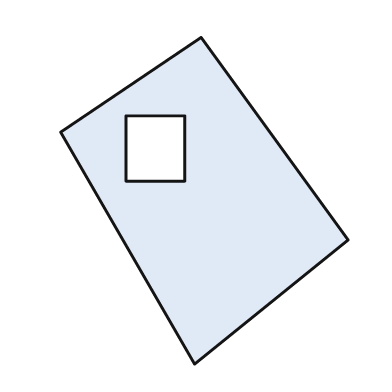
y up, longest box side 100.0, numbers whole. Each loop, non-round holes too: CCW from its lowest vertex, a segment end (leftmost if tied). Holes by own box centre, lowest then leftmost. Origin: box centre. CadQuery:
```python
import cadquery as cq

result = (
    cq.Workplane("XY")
    .moveTo(-3.0, -50.0)
    .lineTo(44.0, -12.0)
    .lineTo(-1.0, 50.0)
    .lineTo(-44.0, 21.0)
    .close()
    .moveTo(-24.0, 6.0)
    .lineTo(-6.0, 6.0)
    .lineTo(-6.0, 26.0)
    .lineTo(-24.0, 26.0)
    .close()
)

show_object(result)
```